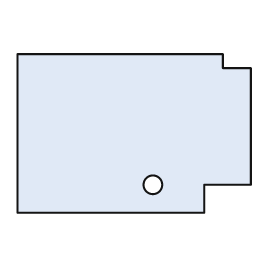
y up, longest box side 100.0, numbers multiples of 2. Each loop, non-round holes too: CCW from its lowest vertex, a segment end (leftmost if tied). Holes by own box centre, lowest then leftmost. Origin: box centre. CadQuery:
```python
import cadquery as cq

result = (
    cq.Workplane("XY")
    .moveTo(-50.0, -34.0)
    .lineTo(30.0, -34.0)
    .lineTo(30.0, -22.0)
    .lineTo(50.0, -22.0)
    .lineTo(50.0, 28.0)
    .lineTo(38.0, 28.0)
    .lineTo(38.0, 34.0)
    .lineTo(-50.0, 34.0)
    .close()
    .moveTo(8.0, -22.0)
    .circle(4.0)
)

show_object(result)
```